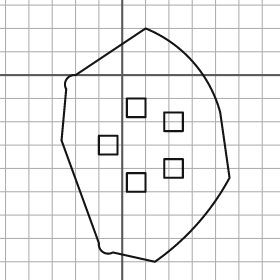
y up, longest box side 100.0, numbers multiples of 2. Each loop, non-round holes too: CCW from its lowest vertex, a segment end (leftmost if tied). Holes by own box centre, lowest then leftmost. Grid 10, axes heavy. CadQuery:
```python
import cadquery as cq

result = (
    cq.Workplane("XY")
    .moveTo(14.0, -80.0)
    .threePointArc((32.0, -64.0), (46.0, -44.0))
    .lineTo(42.0, -16.0)
    .threePointArc((30.0, 6.0), (10.0, 20.0))
    .lineTo(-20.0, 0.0)
    .threePointArc((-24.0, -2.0), (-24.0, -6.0))
    .lineTo(-26.0, -28.0)
    .lineTo(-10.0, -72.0)
    .threePointArc((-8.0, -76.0), (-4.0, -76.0))
    .close()
    .moveTo(2.0, -50.0)
    .lineTo(10.0, -50.0)
    .lineTo(10.0, -42.0)
    .lineTo(2.0, -42.0)
    .close()
    .moveTo(18.0, -44.0)
    .lineTo(26.0, -44.0)
    .lineTo(26.0, -36.0)
    .lineTo(18.0, -36.0)
    .close()
    .moveTo(-10.0, -34.0)
    .lineTo(-2.0, -34.0)
    .lineTo(-2.0, -26.0)
    .lineTo(-10.0, -26.0)
    .close()
    .moveTo(18.0, -24.0)
    .lineTo(26.0, -24.0)
    .lineTo(26.0, -16.0)
    .lineTo(18.0, -16.0)
    .close()
    .moveTo(2.0, -18.0)
    .lineTo(10.0, -18.0)
    .lineTo(10.0, -10.0)
    .lineTo(2.0, -10.0)
    .close()
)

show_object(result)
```